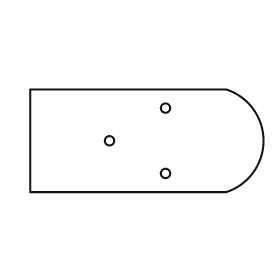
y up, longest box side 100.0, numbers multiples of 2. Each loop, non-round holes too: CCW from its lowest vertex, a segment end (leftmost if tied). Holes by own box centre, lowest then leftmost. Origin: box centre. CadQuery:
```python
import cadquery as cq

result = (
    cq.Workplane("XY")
    .moveTo(-50.0, -22.0)
    .lineTo(34.0, -22.0)
    .threePointArc((50.0, 0.0), (34.0, 22.0))
    .lineTo(-50.0, 22.0)
    .close()
    .moveTo(8.0, -14.0)
    .circle(2.0)
    .moveTo(-16.0, 0.0)
    .circle(2.0)
    .moveTo(8.0, 14.0)
    .circle(2.0)
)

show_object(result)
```